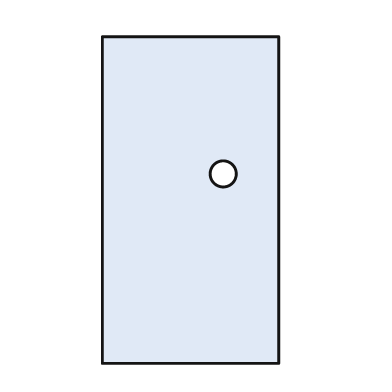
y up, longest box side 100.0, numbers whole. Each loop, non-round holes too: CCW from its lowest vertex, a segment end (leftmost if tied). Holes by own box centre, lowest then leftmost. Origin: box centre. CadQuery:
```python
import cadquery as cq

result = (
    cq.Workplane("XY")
    .moveTo(-27.0, -50.0)
    .lineTo(27.0, -50.0)
    .lineTo(27.0, 50.0)
    .lineTo(-27.0, 50.0)
    .close()
    .moveTo(10.0, 8.0)
    .circle(4.0)
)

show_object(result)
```